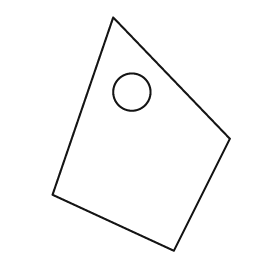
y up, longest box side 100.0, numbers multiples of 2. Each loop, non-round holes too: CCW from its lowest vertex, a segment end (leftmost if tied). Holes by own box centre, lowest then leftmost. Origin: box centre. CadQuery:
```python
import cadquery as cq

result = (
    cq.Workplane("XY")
    .moveTo(14.0, -50.0)
    .lineTo(38.0, -2.0)
    .lineTo(-12.0, 50.0)
    .lineTo(-38.0, -26.0)
    .close()
    .moveTo(-4.0, 18.0)
    .circle(8.0)
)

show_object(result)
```